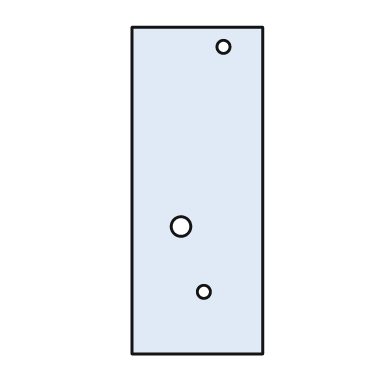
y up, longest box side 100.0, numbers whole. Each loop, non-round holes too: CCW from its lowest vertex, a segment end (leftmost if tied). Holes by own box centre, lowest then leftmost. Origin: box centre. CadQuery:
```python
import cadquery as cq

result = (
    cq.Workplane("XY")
    .moveTo(-20.0, -50.0)
    .lineTo(20.0, -50.0)
    .lineTo(20.0, 50.0)
    .lineTo(-20.0, 50.0)
    .close()
    .moveTo(2.0, -31.0)
    .circle(2.0)
    .moveTo(-5.0, -11.0)
    .circle(3.0)
    .moveTo(8.0, 44.0)
    .circle(2.0)
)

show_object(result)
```